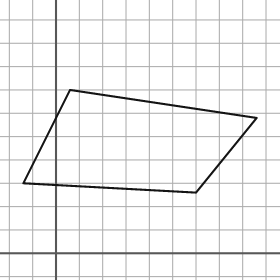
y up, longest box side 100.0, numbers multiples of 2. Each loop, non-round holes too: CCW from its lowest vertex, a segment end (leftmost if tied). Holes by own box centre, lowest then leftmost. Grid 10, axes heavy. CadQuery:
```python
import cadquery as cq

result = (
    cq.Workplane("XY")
    .moveTo(60.0, 26.0)
    .lineTo(86.0, 58.0)
    .lineTo(6.0, 70.0)
    .lineTo(-14.0, 30.0)
    .close()
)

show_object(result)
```